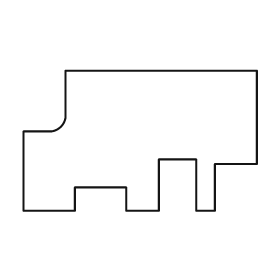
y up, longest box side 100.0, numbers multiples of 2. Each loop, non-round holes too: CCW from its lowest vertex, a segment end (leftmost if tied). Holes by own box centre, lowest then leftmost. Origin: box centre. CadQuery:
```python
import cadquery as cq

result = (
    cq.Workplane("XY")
    .moveTo(-50.0, -30.0)
    .lineTo(-28.0, -30.0)
    .lineTo(-28.0, -20.0)
    .lineTo(-6.0, -20.0)
    .lineTo(-6.0, -30.0)
    .lineTo(8.0, -30.0)
    .lineTo(8.0, -8.0)
    .lineTo(24.0, -8.0)
    .lineTo(24.0, -30.0)
    .lineTo(32.0, -30.0)
    .lineTo(32.0, -10.0)
    .lineTo(50.0, -10.0)
    .lineTo(50.0, 30.0)
    .lineTo(-32.0, 30.0)
    .lineTo(-32.0, 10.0)
    .threePointArc((-34.0, 6.0), (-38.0, 4.0))
    .lineTo(-50.0, 4.0)
    .close()
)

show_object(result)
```